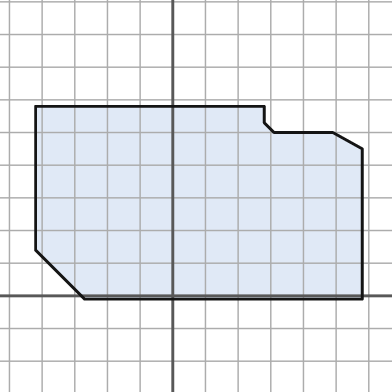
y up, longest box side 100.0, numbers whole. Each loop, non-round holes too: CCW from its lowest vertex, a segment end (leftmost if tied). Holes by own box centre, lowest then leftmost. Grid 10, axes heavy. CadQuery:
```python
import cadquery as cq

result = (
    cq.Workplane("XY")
    .moveTo(-27.0, -1.0)
    .lineTo(58.0, -1.0)
    .lineTo(58.0, 45.0)
    .lineTo(49.0, 50.0)
    .lineTo(31.0, 50.0)
    .lineTo(28.0, 53.0)
    .lineTo(28.0, 58.0)
    .lineTo(-42.0, 58.0)
    .lineTo(-42.0, 14.0)
    .close()
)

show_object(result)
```